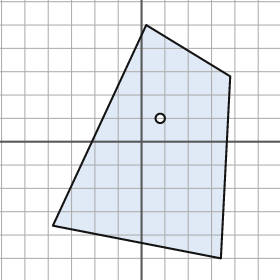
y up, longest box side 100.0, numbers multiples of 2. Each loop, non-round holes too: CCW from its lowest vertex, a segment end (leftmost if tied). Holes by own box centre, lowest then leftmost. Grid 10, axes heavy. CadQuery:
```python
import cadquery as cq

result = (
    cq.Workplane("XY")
    .moveTo(34.0, -50.0)
    .lineTo(38.0, 28.0)
    .lineTo(2.0, 50.0)
    .lineTo(-38.0, -36.0)
    .close()
    .moveTo(8.0, 10.0)
    .circle(2.0)
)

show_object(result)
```